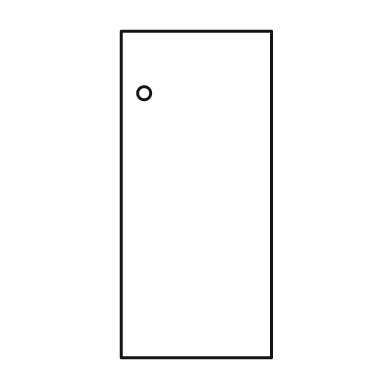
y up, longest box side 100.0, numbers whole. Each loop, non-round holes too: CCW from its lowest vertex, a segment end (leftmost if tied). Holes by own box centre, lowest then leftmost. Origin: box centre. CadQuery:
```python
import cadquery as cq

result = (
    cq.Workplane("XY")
    .moveTo(-23.0, -50.0)
    .lineTo(23.0, -50.0)
    .lineTo(23.0, 50.0)
    .lineTo(-23.0, 50.0)
    .close()
    .moveTo(-16.0, 31.0)
    .circle(2.0)
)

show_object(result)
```